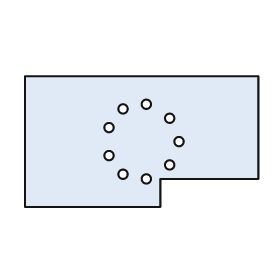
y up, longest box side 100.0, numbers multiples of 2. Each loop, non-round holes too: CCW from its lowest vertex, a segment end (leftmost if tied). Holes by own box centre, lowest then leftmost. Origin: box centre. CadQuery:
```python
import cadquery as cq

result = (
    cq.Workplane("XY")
    .moveTo(-50.0, -28.0)
    .lineTo(8.0, -28.0)
    .lineTo(8.0, -16.0)
    .lineTo(50.0, -16.0)
    .lineTo(50.0, 28.0)
    .lineTo(-50.0, 28.0)
    .close()
    .moveTo(2.0, -16.0)
    .circle(2.0)
    .moveTo(-8.0, -14.0)
    .circle(2.0)
    .moveTo(12.0, -10.0)
    .circle(2.0)
    .moveTo(-14.0, -6.0)
    .circle(2.0)
    .moveTo(16.0, 0.0)
    .circle(2.0)
    .moveTo(-14.0, 6.0)
    .circle(2.0)
    .moveTo(12.0, 10.0)
    .circle(2.0)
    .moveTo(-8.0, 14.0)
    .circle(2.0)
    .moveTo(2.0, 16.0)
    .circle(2.0)
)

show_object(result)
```